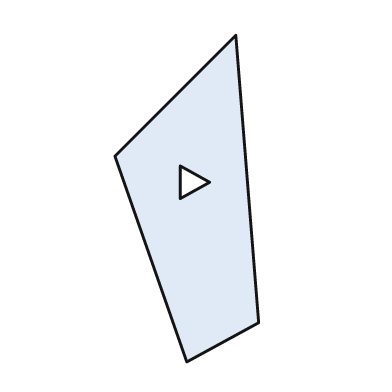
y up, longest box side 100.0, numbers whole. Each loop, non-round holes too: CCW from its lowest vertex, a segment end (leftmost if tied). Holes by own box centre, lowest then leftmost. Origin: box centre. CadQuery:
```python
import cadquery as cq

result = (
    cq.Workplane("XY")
    .moveTo(0.0, -50.0)
    .lineTo(22.0, -38.0)
    .lineTo(15.0, 50.0)
    .lineTo(-22.0, 13.0)
    .close()
    .moveTo(-2.0, 0.0)
    .lineTo(7.0, 5.0)
    .lineTo(-2.0, 10.0)
    .close()
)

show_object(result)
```